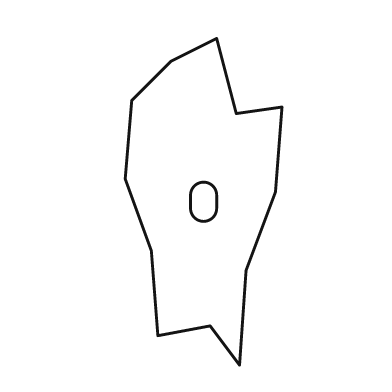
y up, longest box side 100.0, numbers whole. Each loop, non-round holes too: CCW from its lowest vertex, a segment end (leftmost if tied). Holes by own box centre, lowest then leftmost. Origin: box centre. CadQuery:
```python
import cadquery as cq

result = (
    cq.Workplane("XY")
    .moveTo(11.0, -50.0)
    .lineTo(13.0, -21.0)
    .lineTo(22.0, 3.0)
    .lineTo(24.0, 29.0)
    .lineTo(10.0, 27.0)
    .lineTo(4.0, 50.0)
    .lineTo(-10.0, 43.0)
    .lineTo(-22.0, 31.0)
    .lineTo(-24.0, 7.0)
    .lineTo(-16.0, -15.0)
    .lineTo(-14.0, -41.0)
    .lineTo(2.0, -38.0)
    .close()
    .moveTo(-4.0, -2.0)
    .threePointArc((0.0, -6.0), (4.0, -2.0))
    .lineTo(4.0, 2.0)
    .threePointArc((0.0, 6.0), (-4.0, 2.0))
    .close()
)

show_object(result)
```